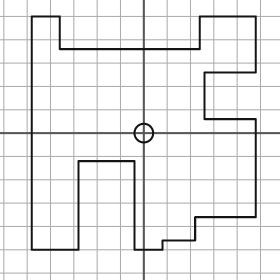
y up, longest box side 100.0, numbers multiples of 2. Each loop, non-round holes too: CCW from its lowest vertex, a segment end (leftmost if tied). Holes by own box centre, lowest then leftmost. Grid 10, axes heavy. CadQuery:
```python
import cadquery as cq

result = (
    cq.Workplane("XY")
    .moveTo(-48.0, -50.0)
    .lineTo(-28.0, -50.0)
    .lineTo(-28.0, -12.0)
    .lineTo(-4.0, -12.0)
    .lineTo(-4.0, -50.0)
    .lineTo(8.0, -50.0)
    .lineTo(8.0, -46.0)
    .lineTo(22.0, -46.0)
    .lineTo(22.0, -36.0)
    .lineTo(48.0, -36.0)
    .lineTo(48.0, 6.0)
    .lineTo(26.0, 6.0)
    .lineTo(26.0, 26.0)
    .lineTo(48.0, 26.0)
    .lineTo(48.0, 50.0)
    .lineTo(24.0, 50.0)
    .lineTo(24.0, 36.0)
    .lineTo(-36.0, 36.0)
    .lineTo(-36.0, 50.0)
    .lineTo(-48.0, 50.0)
    .close()
    .moveTo(0.0, 0.0)
    .circle(4.0)
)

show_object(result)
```